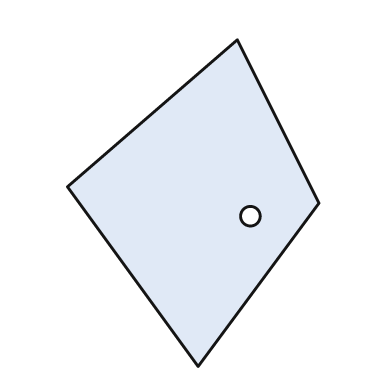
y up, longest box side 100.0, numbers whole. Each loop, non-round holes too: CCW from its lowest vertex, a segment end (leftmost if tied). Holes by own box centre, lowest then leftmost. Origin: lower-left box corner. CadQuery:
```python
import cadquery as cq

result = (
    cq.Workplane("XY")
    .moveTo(40.0, 0.0)
    .lineTo(77.0, 50.0)
    .lineTo(52.0, 100.0)
    .lineTo(0.0, 55.0)
    .close()
    .moveTo(56.0, 46.0)
    .circle(3.0)
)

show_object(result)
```